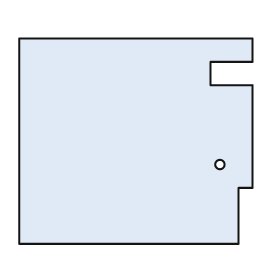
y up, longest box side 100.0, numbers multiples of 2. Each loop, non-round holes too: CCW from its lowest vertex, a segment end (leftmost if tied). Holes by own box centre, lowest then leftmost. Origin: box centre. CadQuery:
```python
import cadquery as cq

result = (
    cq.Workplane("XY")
    .moveTo(-50.0, -44.0)
    .lineTo(44.0, -44.0)
    .lineTo(44.0, -20.0)
    .lineTo(50.0, -20.0)
    .lineTo(50.0, 24.0)
    .lineTo(32.0, 24.0)
    .lineTo(32.0, 34.0)
    .lineTo(50.0, 34.0)
    .lineTo(50.0, 44.0)
    .lineTo(-50.0, 44.0)
    .close()
    .moveTo(36.0, -10.0)
    .circle(2.0)
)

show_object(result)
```